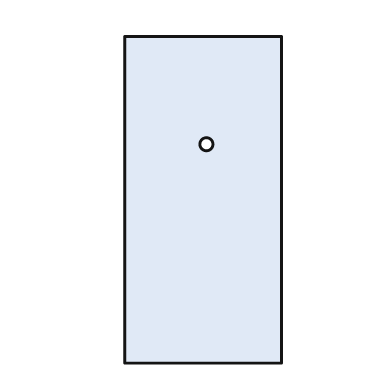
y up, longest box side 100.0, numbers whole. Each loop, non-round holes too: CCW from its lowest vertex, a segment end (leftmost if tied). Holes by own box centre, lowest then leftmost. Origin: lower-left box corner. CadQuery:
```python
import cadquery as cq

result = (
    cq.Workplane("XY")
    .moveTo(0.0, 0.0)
    .lineTo(48.0, 0.0)
    .lineTo(48.0, 100.0)
    .lineTo(0.0, 100.0)
    .close()
    .moveTo(25.0, 67.0)
    .circle(2.0)
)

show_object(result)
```